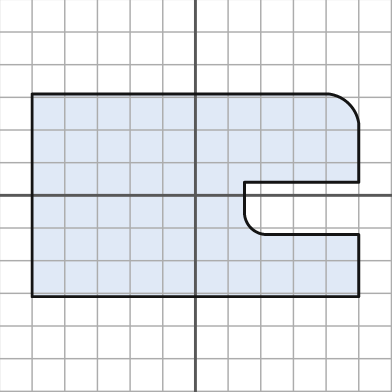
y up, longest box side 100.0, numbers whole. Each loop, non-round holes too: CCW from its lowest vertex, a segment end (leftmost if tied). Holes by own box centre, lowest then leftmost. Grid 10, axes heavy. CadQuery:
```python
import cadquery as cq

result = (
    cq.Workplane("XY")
    .moveTo(-50.0, -31.0)
    .lineTo(50.0, -31.0)
    .lineTo(50.0, -12.0)
    .lineTo(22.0, -12.0)
    .threePointArc((17.0, -10.0), (15.0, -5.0))
    .lineTo(15.0, 4.0)
    .lineTo(50.0, 4.0)
    .lineTo(50.0, 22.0)
    .threePointArc((47.0, 28.0), (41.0, 31.0))
    .lineTo(-50.0, 31.0)
    .close()
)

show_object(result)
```